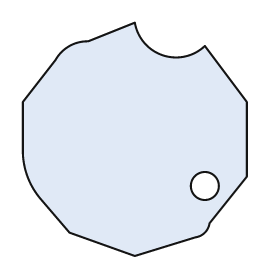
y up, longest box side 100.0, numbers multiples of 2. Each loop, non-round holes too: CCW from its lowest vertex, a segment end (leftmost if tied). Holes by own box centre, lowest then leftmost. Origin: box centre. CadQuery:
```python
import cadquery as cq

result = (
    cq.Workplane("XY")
    .moveTo(0.0, -50.0)
    .lineTo(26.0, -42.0)
    .threePointArc((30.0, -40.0), (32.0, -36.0))
    .lineTo(48.0, -16.0)
    .lineTo(48.0, 16.0)
    .lineTo(30.0, 40.0)
    .threePointArc((12.0, 36.0), (0.0, 50.0))
    .lineTo(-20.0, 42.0)
    .threePointArc((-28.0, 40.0), (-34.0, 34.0))
    .lineTo(-48.0, 16.0)
    .lineTo(-48.0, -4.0)
    .threePointArc((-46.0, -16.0), (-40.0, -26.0))
    .lineTo(-28.0, -40.0)
    .close()
    .moveTo(30.0, -20.0)
    .circle(6.0)
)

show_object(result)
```